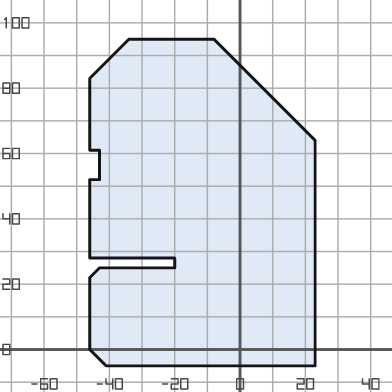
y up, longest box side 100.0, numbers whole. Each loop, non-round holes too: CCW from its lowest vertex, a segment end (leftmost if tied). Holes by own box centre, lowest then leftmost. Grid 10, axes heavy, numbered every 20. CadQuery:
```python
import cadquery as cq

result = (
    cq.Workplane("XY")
    .moveTo(-41.0, -5.0)
    .lineTo(23.0, -5.0)
    .lineTo(23.0, 64.0)
    .lineTo(-8.0, 95.0)
    .lineTo(-34.0, 95.0)
    .lineTo(-46.0, 83.0)
    .lineTo(-46.0, 61.0)
    .lineTo(-43.0, 61.0)
    .lineTo(-43.0, 52.0)
    .lineTo(-46.0, 52.0)
    .lineTo(-46.0, 28.0)
    .lineTo(-20.0, 28.0)
    .lineTo(-20.0, 25.0)
    .lineTo(-43.0, 25.0)
    .lineTo(-46.0, 22.0)
    .lineTo(-46.0, 0.0)
    .close()
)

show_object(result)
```